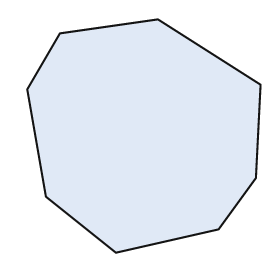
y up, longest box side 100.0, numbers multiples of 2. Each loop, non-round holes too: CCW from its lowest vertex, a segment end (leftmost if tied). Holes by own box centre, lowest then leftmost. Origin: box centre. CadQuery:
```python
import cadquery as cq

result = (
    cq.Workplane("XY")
    .moveTo(-12.0, -50.0)
    .lineTo(32.0, -40.0)
    .lineTo(48.0, -18.0)
    .lineTo(50.0, 22.0)
    .lineTo(6.0, 50.0)
    .lineTo(-36.0, 44.0)
    .lineTo(-50.0, 20.0)
    .lineTo(-42.0, -26.0)
    .close()
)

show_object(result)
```